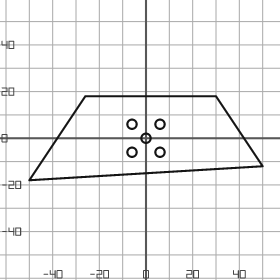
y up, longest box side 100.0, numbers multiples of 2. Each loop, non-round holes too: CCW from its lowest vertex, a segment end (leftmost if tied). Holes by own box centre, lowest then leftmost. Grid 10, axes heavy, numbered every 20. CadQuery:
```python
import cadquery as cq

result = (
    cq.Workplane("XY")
    .moveTo(-50.0, -18.0)
    .lineTo(50.0, -12.0)
    .lineTo(30.0, 18.0)
    .lineTo(-26.0, 18.0)
    .close()
    .moveTo(-6.0, -6.0)
    .circle(2.0)
    .moveTo(6.0, -6.0)
    .circle(2.0)
    .moveTo(0.0, 0.0)
    .circle(2.0)
    .moveTo(-6.0, 6.0)
    .circle(2.0)
    .moveTo(6.0, 6.0)
    .circle(2.0)
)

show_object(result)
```